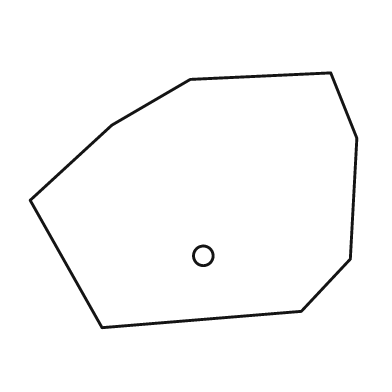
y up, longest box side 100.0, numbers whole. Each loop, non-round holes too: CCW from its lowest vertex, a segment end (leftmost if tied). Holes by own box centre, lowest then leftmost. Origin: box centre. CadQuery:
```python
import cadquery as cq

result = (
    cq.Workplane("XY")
    .moveTo(-28.0, -39.0)
    .lineTo(33.0, -34.0)
    .lineTo(48.0, -18.0)
    .lineTo(50.0, 19.0)
    .lineTo(42.0, 39.0)
    .lineTo(-1.0, 37.0)
    .lineTo(-25.0, 23.0)
    .lineTo(-50.0, 0.0)
    .close()
    .moveTo(3.0, -17.0)
    .circle(3.0)
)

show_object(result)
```